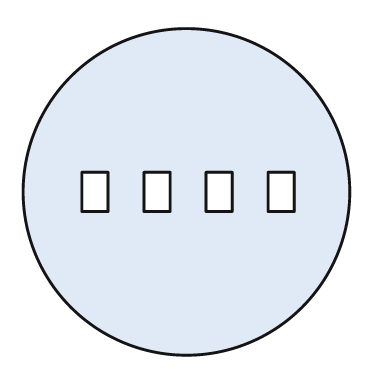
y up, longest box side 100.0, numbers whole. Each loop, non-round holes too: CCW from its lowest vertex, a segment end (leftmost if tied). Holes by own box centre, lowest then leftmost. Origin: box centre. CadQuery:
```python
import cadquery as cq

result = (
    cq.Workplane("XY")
    .moveTo(0.0, 0.0)
    .circle(50.0)
    .moveTo(-32.0, -6.0)
    .lineTo(-24.0, -6.0)
    .lineTo(-24.0, 6.0)
    .lineTo(-32.0, 6.0)
    .close()
    .moveTo(-13.0, -6.0)
    .lineTo(-5.0, -6.0)
    .lineTo(-5.0, 6.0)
    .lineTo(-13.0, 6.0)
    .close()
    .moveTo(6.0, -6.0)
    .lineTo(14.0, -6.0)
    .lineTo(14.0, 6.0)
    .lineTo(6.0, 6.0)
    .close()
    .moveTo(25.0, -6.0)
    .lineTo(33.0, -6.0)
    .lineTo(33.0, 6.0)
    .lineTo(25.0, 6.0)
    .close()
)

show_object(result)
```